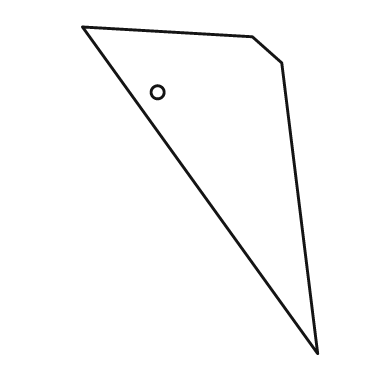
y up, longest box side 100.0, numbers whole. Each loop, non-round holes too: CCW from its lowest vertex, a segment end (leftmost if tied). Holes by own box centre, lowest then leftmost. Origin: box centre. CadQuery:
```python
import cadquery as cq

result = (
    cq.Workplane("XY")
    .moveTo(36.0, -50.0)
    .lineTo(25.0, 39.0)
    .lineTo(16.0, 47.0)
    .lineTo(-36.0, 50.0)
    .close()
    .moveTo(-13.0, 30.0)
    .circle(2.0)
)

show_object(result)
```